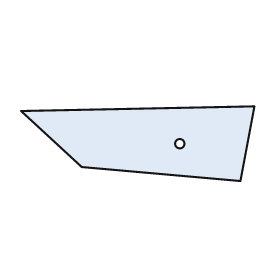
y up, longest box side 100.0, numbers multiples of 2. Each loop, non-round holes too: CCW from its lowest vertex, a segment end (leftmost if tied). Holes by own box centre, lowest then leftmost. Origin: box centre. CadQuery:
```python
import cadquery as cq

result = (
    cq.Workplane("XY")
    .moveTo(44.0, -16.0)
    .lineTo(50.0, 16.0)
    .lineTo(-50.0, 14.0)
    .lineTo(-24.0, -10.0)
    .close()
    .moveTo(18.0, 0.0)
    .circle(2.0)
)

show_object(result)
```